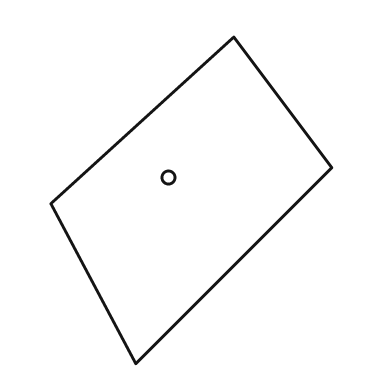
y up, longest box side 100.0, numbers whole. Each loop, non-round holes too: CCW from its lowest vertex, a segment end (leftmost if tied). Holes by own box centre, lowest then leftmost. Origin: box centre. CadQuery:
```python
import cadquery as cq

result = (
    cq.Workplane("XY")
    .moveTo(-17.0, -50.0)
    .lineTo(43.0, 10.0)
    .lineTo(13.0, 50.0)
    .lineTo(-43.0, -1.0)
    .close()
    .moveTo(-7.0, 7.0)
    .circle(2.0)
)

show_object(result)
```